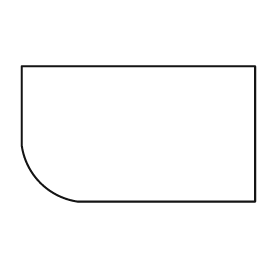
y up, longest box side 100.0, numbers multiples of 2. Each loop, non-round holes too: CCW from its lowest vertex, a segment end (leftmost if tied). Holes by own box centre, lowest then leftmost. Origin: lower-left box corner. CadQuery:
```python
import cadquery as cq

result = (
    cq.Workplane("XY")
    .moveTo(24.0, 0.0)
    .lineTo(100.0, 0.0)
    .lineTo(100.0, 58.0)
    .lineTo(0.0, 58.0)
    .lineTo(0.0, 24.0)
    .threePointArc((8.0, 8.0), (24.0, 0.0))
    .close()
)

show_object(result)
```